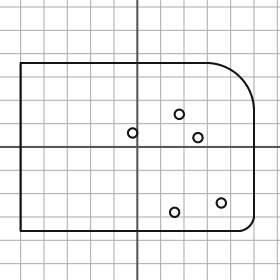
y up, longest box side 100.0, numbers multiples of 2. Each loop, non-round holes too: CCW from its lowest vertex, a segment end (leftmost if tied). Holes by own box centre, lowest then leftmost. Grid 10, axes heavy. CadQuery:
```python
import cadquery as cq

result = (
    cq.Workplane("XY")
    .moveTo(-50.0, -36.0)
    .lineTo(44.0, -36.0)
    .threePointArc((48.0, -34.0), (50.0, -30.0))
    .lineTo(50.0, 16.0)
    .threePointArc((44.0, 30.0), (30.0, 36.0))
    .lineTo(-50.0, 36.0)
    .close()
    .moveTo(16.0, -28.0)
    .circle(2.0)
    .moveTo(36.0, -24.0)
    .circle(2.0)
    .moveTo(26.0, 4.0)
    .circle(2.0)
    .moveTo(-2.0, 6.0)
    .circle(2.0)
    .moveTo(18.0, 14.0)
    .circle(2.0)
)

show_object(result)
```